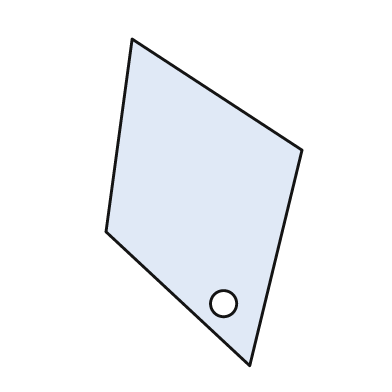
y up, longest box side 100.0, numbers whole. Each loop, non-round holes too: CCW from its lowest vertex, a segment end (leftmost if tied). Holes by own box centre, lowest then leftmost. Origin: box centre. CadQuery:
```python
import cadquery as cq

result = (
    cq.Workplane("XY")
    .moveTo(14.0, -50.0)
    .lineTo(30.0, 16.0)
    .lineTo(-22.0, 50.0)
    .lineTo(-30.0, -9.0)
    .close()
    .moveTo(6.0, -31.0)
    .circle(4.0)
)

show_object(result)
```